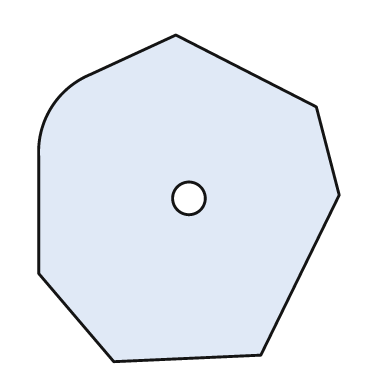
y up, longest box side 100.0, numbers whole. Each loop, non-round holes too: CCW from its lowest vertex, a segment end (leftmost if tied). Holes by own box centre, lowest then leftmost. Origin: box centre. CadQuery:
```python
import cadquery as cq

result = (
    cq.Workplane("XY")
    .moveTo(-23.0, -50.0)
    .lineTo(22.0, -48.0)
    .lineTo(46.0, 1.0)
    .lineTo(39.0, 28.0)
    .lineTo(-4.0, 50.0)
    .lineTo(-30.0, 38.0)
    .threePointArc((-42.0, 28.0), (-46.0, 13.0))
    .lineTo(-46.0, -23.0)
    .close()
    .moveTo(0.0, 0.0)
    .circle(5.0)
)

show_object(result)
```